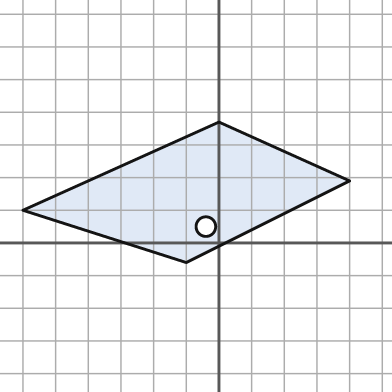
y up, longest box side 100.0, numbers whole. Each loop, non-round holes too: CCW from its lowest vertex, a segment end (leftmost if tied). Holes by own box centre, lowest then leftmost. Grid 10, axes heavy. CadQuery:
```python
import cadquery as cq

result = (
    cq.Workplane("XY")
    .moveTo(-10.0, -6.0)
    .lineTo(40.0, 19.0)
    .lineTo(0.0, 37.0)
    .lineTo(-60.0, 10.0)
    .close()
    .moveTo(-4.0, 5.0)
    .circle(3.0)
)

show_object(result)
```